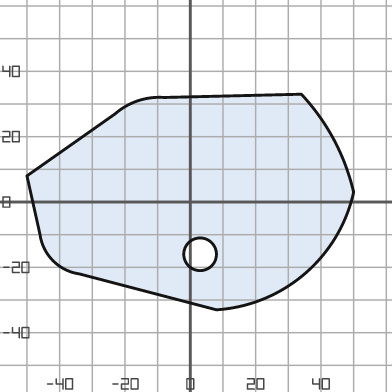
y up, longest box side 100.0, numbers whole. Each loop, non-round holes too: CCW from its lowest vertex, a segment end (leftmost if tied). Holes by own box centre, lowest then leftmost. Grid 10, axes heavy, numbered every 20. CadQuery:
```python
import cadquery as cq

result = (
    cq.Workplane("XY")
    .moveTo(8.0, -33.0)
    .threePointArc((35.0, -22.0), (50.0, 3.0))
    .threePointArc((44.0, 19.0), (34.0, 33.0))
    .lineTo(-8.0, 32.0)
    .threePointArc((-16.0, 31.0), (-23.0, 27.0))
    .lineTo(-50.0, 8.0)
    .lineTo(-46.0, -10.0)
    .threePointArc((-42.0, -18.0), (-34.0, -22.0))
    .close()
    .moveTo(3.0, -16.0)
    .circle(5.0)
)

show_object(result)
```